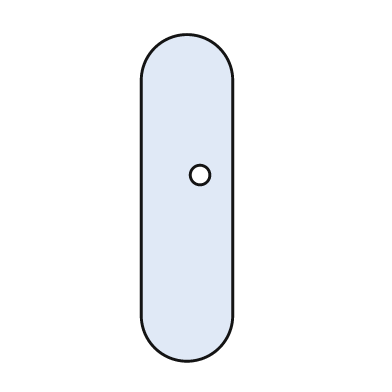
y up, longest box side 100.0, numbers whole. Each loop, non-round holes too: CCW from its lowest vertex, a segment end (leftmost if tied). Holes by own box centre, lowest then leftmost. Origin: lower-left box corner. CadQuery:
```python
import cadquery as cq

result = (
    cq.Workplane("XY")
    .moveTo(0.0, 14.0)
    .threePointArc((14.0, 0.0), (28.0, 14.0))
    .lineTo(28.0, 86.0)
    .threePointArc((14.0, 100.0), (0.0, 86.0))
    .close()
    .moveTo(18.0, 57.0)
    .circle(3.0)
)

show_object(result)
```